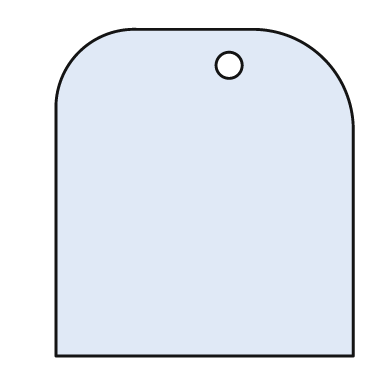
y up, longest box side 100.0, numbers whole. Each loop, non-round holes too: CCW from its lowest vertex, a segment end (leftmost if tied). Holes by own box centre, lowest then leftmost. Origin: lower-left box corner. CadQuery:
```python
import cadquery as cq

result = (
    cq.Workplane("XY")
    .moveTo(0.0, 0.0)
    .lineTo(91.0, 0.0)
    .lineTo(91.0, 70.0)
    .threePointArc((82.0, 91.0), (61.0, 100.0))
    .lineTo(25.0, 100.0)
    .threePointArc((7.0, 93.0), (0.0, 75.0))
    .close()
    .moveTo(53.0, 89.0)
    .circle(4.0)
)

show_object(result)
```